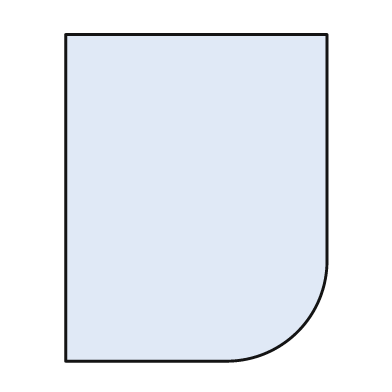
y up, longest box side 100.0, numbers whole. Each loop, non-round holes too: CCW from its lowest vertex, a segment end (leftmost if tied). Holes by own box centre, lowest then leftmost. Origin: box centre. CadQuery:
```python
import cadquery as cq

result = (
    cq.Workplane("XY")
    .moveTo(-40.0, -50.0)
    .lineTo(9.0, -50.0)
    .threePointArc((31.0, -41.0), (40.0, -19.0))
    .lineTo(40.0, 50.0)
    .lineTo(-40.0, 50.0)
    .close()
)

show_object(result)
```